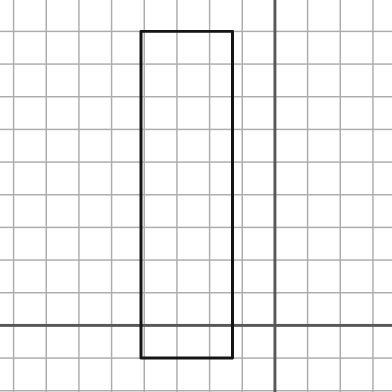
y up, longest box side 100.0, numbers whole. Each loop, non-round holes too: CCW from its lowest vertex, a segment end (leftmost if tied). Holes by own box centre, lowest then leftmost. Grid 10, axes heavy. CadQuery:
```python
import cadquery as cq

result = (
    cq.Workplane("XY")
    .moveTo(-41.0, -10.0)
    .lineTo(-13.0, -10.0)
    .lineTo(-13.0, 90.0)
    .lineTo(-41.0, 90.0)
    .close()
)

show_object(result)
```